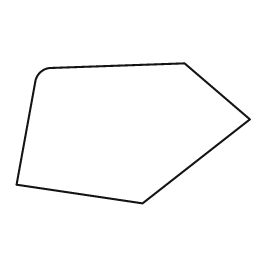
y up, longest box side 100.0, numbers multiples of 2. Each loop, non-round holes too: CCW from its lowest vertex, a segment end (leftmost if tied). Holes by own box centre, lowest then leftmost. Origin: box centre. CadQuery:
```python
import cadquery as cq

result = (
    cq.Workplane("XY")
    .moveTo(4.0, -30.0)
    .lineTo(50.0, 6.0)
    .lineTo(22.0, 30.0)
    .lineTo(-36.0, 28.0)
    .threePointArc((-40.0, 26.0), (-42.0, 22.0))
    .lineTo(-50.0, -22.0)
    .close()
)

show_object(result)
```